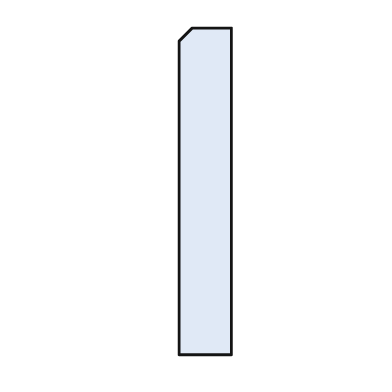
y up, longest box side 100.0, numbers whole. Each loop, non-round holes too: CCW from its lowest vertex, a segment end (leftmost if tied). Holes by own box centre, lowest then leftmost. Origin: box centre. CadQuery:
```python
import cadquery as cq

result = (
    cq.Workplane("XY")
    .moveTo(-8.0, -50.0)
    .lineTo(8.0, -50.0)
    .lineTo(8.0, 50.0)
    .lineTo(-4.0, 50.0)
    .lineTo(-8.0, 46.0)
    .close()
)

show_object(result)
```